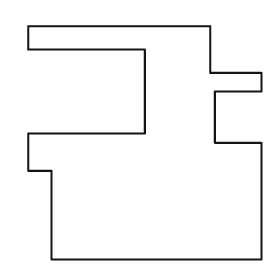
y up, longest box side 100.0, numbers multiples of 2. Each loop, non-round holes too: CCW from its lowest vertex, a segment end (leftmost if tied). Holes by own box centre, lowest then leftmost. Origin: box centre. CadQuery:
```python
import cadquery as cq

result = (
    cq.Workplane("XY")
    .moveTo(-40.0, -50.0)
    .lineTo(50.0, -50.0)
    .lineTo(50.0, 0.0)
    .lineTo(30.0, 0.0)
    .lineTo(30.0, 22.0)
    .lineTo(50.0, 22.0)
    .lineTo(50.0, 30.0)
    .lineTo(28.0, 30.0)
    .lineTo(28.0, 50.0)
    .lineTo(-50.0, 50.0)
    .lineTo(-50.0, 40.0)
    .lineTo(0.0, 40.0)
    .lineTo(0.0, 4.0)
    .lineTo(-50.0, 4.0)
    .lineTo(-50.0, -12.0)
    .lineTo(-40.0, -12.0)
    .close()
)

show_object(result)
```